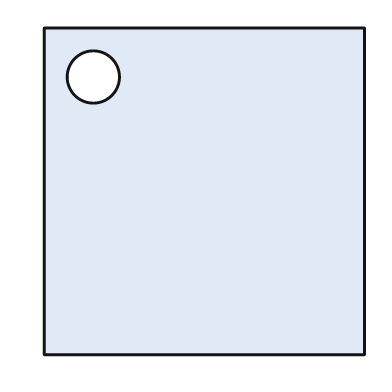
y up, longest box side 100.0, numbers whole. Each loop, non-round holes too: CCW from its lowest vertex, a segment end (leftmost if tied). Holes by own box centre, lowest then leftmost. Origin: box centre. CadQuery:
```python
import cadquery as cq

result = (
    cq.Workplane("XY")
    .moveTo(-49.0, -50.0)
    .lineTo(49.0, -50.0)
    .lineTo(49.0, 50.0)
    .lineTo(-49.0, 50.0)
    .close()
    .moveTo(-34.0, 35.0)
    .circle(8.0)
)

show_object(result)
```